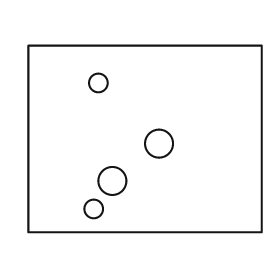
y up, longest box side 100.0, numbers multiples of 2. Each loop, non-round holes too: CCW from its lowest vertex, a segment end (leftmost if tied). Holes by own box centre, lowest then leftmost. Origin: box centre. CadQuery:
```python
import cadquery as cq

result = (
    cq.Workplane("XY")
    .moveTo(-50.0, -40.0)
    .lineTo(50.0, -40.0)
    .lineTo(50.0, 40.0)
    .lineTo(-50.0, 40.0)
    .close()
    .moveTo(-22.0, -30.0)
    .circle(4.0)
    .moveTo(-14.0, -18.0)
    .circle(6.0)
    .moveTo(6.0, -2.0)
    .circle(6.0)
    .moveTo(-20.0, 24.0)
    .circle(4.0)
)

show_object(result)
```